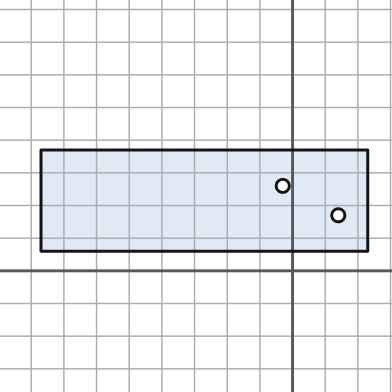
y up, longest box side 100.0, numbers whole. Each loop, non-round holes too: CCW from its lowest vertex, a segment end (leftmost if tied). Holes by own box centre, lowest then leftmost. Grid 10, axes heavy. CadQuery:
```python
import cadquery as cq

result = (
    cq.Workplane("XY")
    .moveTo(-77.0, 6.0)
    .lineTo(23.0, 6.0)
    .lineTo(23.0, 37.0)
    .lineTo(-77.0, 37.0)
    .close()
    .moveTo(14.0, 17.0)
    .circle(2.0)
    .moveTo(-3.0, 26.0)
    .circle(2.0)
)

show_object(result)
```